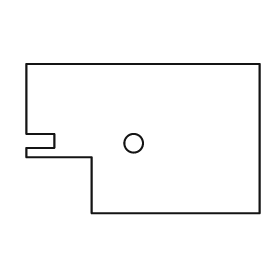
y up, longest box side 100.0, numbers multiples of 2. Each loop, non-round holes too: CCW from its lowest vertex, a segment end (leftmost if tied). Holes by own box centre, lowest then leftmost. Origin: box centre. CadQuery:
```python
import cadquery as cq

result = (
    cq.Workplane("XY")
    .moveTo(-22.0, -32.0)
    .lineTo(50.0, -32.0)
    .lineTo(50.0, 32.0)
    .lineTo(-50.0, 32.0)
    .lineTo(-50.0, 2.0)
    .lineTo(-38.0, 2.0)
    .lineTo(-38.0, -4.0)
    .lineTo(-50.0, -4.0)
    .lineTo(-50.0, -8.0)
    .lineTo(-22.0, -8.0)
    .close()
    .moveTo(-4.0, -2.0)
    .circle(4.0)
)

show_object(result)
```